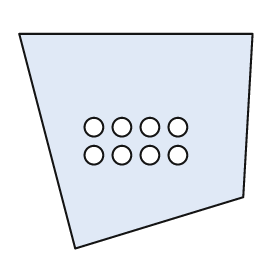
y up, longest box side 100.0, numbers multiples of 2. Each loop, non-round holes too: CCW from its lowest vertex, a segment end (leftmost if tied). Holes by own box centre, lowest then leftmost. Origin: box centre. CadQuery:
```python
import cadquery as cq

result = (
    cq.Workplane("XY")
    .moveTo(-26.0, -46.0)
    .lineTo(46.0, -24.0)
    .lineTo(50.0, 46.0)
    .lineTo(-50.0, 46.0)
    .close()
    .moveTo(-18.0, -6.0)
    .circle(4.0)
    .moveTo(-6.0, -6.0)
    .circle(4.0)
    .moveTo(6.0, -6.0)
    .circle(4.0)
    .moveTo(18.0, -6.0)
    .circle(4.0)
    .moveTo(-18.0, 6.0)
    .circle(4.0)
    .moveTo(-6.0, 6.0)
    .circle(4.0)
    .moveTo(6.0, 6.0)
    .circle(4.0)
    .moveTo(18.0, 6.0)
    .circle(4.0)
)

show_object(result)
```